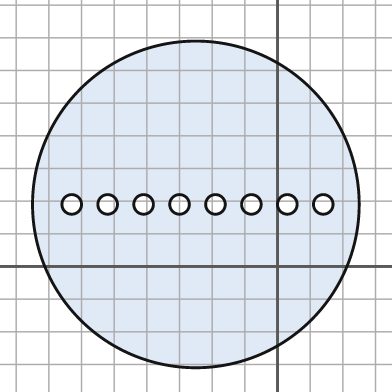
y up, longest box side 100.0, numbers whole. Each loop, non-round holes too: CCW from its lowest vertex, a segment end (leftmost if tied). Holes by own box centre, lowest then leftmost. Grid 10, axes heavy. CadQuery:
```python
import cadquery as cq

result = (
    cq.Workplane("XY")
    .moveTo(-25.0, 19.0)
    .circle(50.0)
    .moveTo(-63.0, 19.0)
    .circle(3.0)
    .moveTo(-52.0, 19.0)
    .circle(3.0)
    .moveTo(-41.0, 19.0)
    .circle(3.0)
    .moveTo(-30.0, 19.0)
    .circle(3.0)
    .moveTo(-19.0, 19.0)
    .circle(3.0)
    .moveTo(-8.0, 19.0)
    .circle(3.0)
    .moveTo(3.0, 19.0)
    .circle(3.0)
    .moveTo(14.0, 19.0)
    .circle(3.0)
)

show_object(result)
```